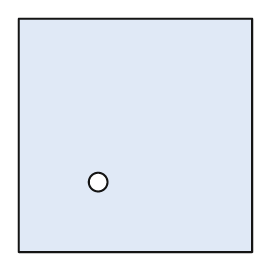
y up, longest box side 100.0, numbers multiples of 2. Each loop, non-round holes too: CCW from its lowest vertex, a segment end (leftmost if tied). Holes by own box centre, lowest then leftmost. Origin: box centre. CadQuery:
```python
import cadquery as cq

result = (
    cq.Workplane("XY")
    .moveTo(-50.0, -50.0)
    .lineTo(50.0, -50.0)
    .lineTo(50.0, 50.0)
    .lineTo(-50.0, 50.0)
    .close()
    .moveTo(-16.0, -20.0)
    .circle(4.0)
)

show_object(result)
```